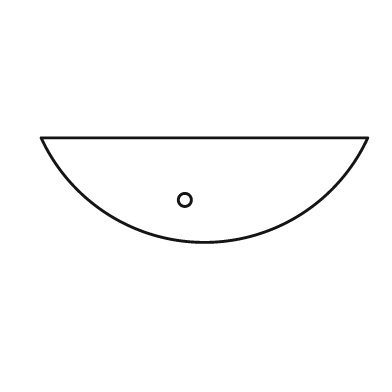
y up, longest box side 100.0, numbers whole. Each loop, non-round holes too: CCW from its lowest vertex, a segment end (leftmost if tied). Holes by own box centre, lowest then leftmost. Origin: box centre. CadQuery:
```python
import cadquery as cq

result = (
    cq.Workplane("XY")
    .moveTo(-50.0, 16.0)
    .threePointArc((0.0, -16.0), (50.0, 16.0))
    .close()
    .moveTo(-6.0, -3.0)
    .circle(2.0)
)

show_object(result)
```